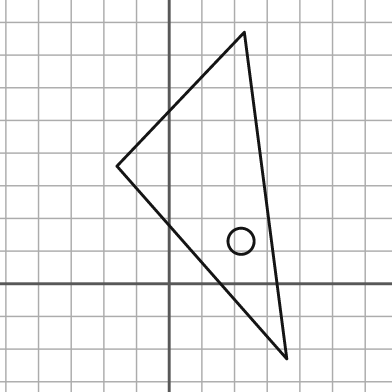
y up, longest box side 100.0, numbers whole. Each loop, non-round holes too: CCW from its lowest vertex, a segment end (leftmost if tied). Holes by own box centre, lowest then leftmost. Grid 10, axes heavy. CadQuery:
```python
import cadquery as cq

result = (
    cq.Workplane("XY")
    .moveTo(36.0, -23.0)
    .lineTo(23.0, 77.0)
    .lineTo(-16.0, 36.0)
    .close()
    .moveTo(22.0, 13.0)
    .circle(4.0)
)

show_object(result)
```